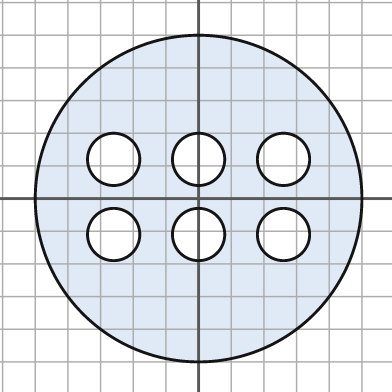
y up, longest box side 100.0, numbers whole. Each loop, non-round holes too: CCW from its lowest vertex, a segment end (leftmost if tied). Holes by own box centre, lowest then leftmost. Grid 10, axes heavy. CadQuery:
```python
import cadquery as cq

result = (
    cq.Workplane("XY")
    .moveTo(0.0, 0.0)
    .circle(50.0)
    .moveTo(-26.0, -11.0)
    .circle(8.0)
    .moveTo(0.0, -11.0)
    .circle(8.0)
    .moveTo(26.0, -11.0)
    .circle(8.0)
    .moveTo(-26.0, 12.0)
    .circle(8.0)
    .moveTo(0.0, 12.0)
    .circle(8.0)
    .moveTo(26.0, 12.0)
    .circle(8.0)
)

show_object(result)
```